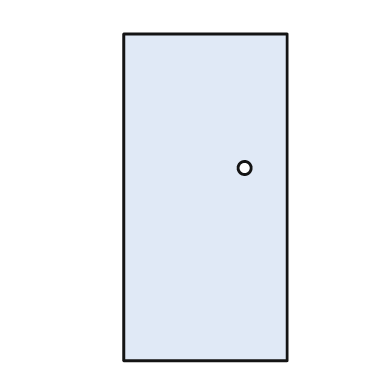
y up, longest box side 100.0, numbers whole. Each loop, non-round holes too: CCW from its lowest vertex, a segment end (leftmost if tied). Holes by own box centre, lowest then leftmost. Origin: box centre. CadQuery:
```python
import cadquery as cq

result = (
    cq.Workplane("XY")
    .moveTo(-25.0, -50.0)
    .lineTo(25.0, -50.0)
    .lineTo(25.0, 50.0)
    .lineTo(-25.0, 50.0)
    .close()
    .moveTo(12.0, 9.0)
    .circle(2.0)
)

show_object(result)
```